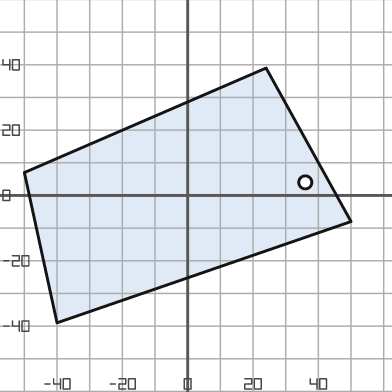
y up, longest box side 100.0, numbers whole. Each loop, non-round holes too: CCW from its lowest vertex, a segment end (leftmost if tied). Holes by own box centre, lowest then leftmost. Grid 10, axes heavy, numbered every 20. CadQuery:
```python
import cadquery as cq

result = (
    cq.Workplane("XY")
    .moveTo(-40.0, -39.0)
    .lineTo(50.0, -8.0)
    .lineTo(24.0, 39.0)
    .lineTo(-50.0, 7.0)
    .close()
    .moveTo(36.0, 4.0)
    .circle(2.0)
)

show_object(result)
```